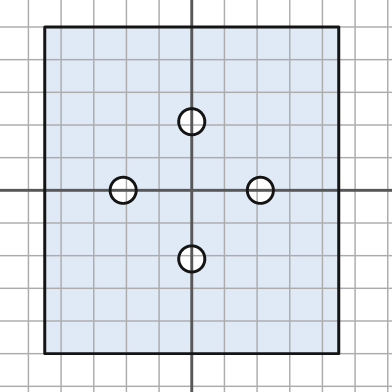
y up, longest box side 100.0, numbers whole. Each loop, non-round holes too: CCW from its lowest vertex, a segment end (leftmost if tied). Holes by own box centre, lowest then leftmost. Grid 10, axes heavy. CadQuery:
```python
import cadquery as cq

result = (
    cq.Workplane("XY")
    .moveTo(-45.0, -50.0)
    .lineTo(45.0, -50.0)
    .lineTo(45.0, 50.0)
    .lineTo(-45.0, 50.0)
    .close()
    .moveTo(0.0, -21.0)
    .circle(4.0)
    .moveTo(-21.0, 0.0)
    .circle(4.0)
    .moveTo(21.0, 0.0)
    .circle(4.0)
    .moveTo(0.0, 21.0)
    .circle(4.0)
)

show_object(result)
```